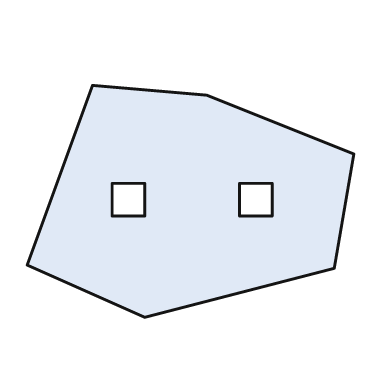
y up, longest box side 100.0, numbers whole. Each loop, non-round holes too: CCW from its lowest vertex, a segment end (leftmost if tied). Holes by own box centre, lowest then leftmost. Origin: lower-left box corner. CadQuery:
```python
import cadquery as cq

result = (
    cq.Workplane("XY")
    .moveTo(36.0, 0.0)
    .lineTo(94.0, 15.0)
    .lineTo(100.0, 50.0)
    .lineTo(55.0, 68.0)
    .lineTo(20.0, 71.0)
    .lineTo(0.0, 16.0)
    .close()
    .moveTo(26.0, 31.0)
    .lineTo(36.0, 31.0)
    .lineTo(36.0, 41.0)
    .lineTo(26.0, 41.0)
    .close()
    .moveTo(65.0, 31.0)
    .lineTo(75.0, 31.0)
    .lineTo(75.0, 41.0)
    .lineTo(65.0, 41.0)
    .close()
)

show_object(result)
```